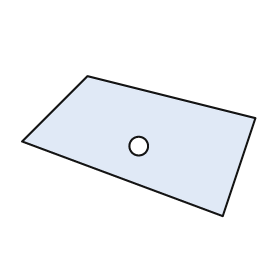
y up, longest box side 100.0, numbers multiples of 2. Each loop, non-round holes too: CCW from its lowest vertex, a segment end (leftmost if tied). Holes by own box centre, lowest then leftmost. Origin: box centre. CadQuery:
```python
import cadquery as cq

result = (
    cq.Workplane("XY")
    .moveTo(36.0, -30.0)
    .lineTo(50.0, 12.0)
    .lineTo(-22.0, 30.0)
    .lineTo(-50.0, 2.0)
    .close()
    .moveTo(0.0, 0.0)
    .circle(4.0)
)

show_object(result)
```